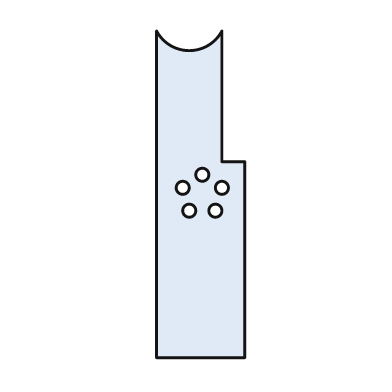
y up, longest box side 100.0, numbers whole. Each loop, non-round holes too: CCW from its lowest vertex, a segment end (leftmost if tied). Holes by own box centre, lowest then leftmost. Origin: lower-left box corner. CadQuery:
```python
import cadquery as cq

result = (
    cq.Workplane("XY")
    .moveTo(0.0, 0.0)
    .lineTo(27.0, 0.0)
    .lineTo(27.0, 60.0)
    .lineTo(20.0, 60.0)
    .lineTo(20.0, 100.0)
    .threePointArc((10.0, 94.0), (0.0, 100.0))
    .close()
    .moveTo(10.0, 45.0)
    .circle(2.0)
    .moveTo(18.0, 45.0)
    .circle(2.0)
    .moveTo(8.0, 52.0)
    .circle(2.0)
    .moveTo(20.0, 52.0)
    .circle(2.0)
    .moveTo(14.0, 56.0)
    .circle(2.0)
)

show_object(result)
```